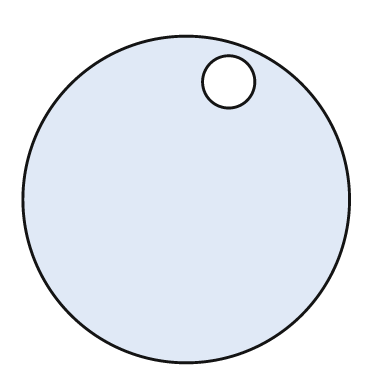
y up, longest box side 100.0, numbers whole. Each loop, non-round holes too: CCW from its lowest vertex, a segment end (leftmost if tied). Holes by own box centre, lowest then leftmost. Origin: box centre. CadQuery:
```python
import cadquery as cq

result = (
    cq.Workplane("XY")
    .moveTo(0.0, 0.0)
    .circle(50.0)
    .moveTo(13.0, 36.0)
    .circle(8.0)
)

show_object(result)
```